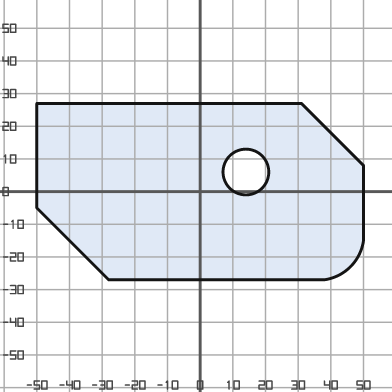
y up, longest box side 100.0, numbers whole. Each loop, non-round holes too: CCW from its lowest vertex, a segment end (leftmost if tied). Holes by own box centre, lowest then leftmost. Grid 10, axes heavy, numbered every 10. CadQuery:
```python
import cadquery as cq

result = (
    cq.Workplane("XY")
    .moveTo(-28.0, -27.0)
    .lineTo(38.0, -27.0)
    .threePointArc((46.0, -23.0), (50.0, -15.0))
    .lineTo(50.0, 8.0)
    .lineTo(31.0, 27.0)
    .lineTo(-50.0, 27.0)
    .lineTo(-50.0, -5.0)
    .close()
    .moveTo(14.0, 6.0)
    .circle(7.0)
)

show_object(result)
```